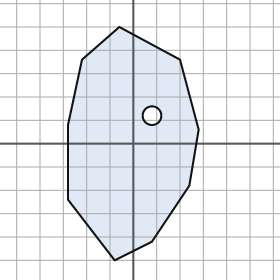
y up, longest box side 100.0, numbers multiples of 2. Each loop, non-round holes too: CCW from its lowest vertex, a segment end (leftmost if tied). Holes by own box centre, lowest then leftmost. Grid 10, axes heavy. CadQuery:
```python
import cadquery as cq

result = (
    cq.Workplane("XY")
    .moveTo(-8.0, -50.0)
    .lineTo(8.0, -42.0)
    .lineTo(24.0, -18.0)
    .lineTo(28.0, 6.0)
    .lineTo(20.0, 36.0)
    .lineTo(-6.0, 50.0)
    .lineTo(-22.0, 36.0)
    .lineTo(-28.0, 8.0)
    .lineTo(-28.0, -24.0)
    .close()
    .moveTo(8.0, 12.0)
    .circle(4.0)
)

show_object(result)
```